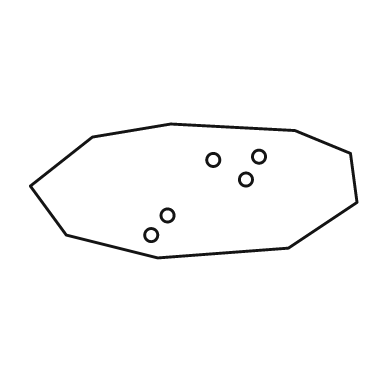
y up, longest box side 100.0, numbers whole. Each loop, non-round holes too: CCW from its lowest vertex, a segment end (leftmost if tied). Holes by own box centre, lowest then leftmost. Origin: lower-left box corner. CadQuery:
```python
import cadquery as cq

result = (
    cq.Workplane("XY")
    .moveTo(39.0, 0.0)
    .lineTo(79.0, 3.0)
    .lineTo(100.0, 17.0)
    .lineTo(98.0, 32.0)
    .lineTo(81.0, 39.0)
    .lineTo(43.0, 41.0)
    .lineTo(19.0, 37.0)
    .lineTo(0.0, 22.0)
    .lineTo(11.0, 7.0)
    .close()
    .moveTo(37.0, 7.0)
    .circle(2.0)
    .moveTo(42.0, 13.0)
    .circle(2.0)
    .moveTo(66.0, 24.0)
    .circle(2.0)
    .moveTo(56.0, 30.0)
    .circle(2.0)
    .moveTo(70.0, 31.0)
    .circle(2.0)
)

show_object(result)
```